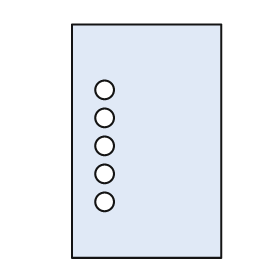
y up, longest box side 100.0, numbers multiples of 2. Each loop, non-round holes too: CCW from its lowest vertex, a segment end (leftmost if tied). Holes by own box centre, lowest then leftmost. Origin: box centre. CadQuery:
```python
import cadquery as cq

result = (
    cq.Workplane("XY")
    .moveTo(-32.0, -50.0)
    .lineTo(32.0, -50.0)
    .lineTo(32.0, 50.0)
    .lineTo(-32.0, 50.0)
    .close()
    .moveTo(-18.0, -26.0)
    .circle(4.0)
    .moveTo(-18.0, -14.0)
    .circle(4.0)
    .moveTo(-18.0, -2.0)
    .circle(4.0)
    .moveTo(-18.0, 10.0)
    .circle(4.0)
    .moveTo(-18.0, 22.0)
    .circle(4.0)
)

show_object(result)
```